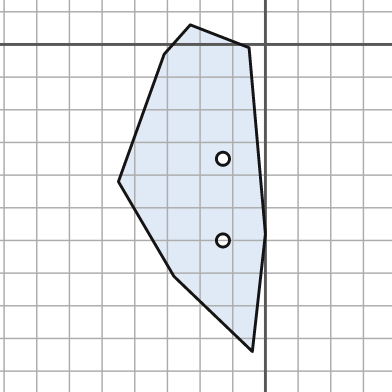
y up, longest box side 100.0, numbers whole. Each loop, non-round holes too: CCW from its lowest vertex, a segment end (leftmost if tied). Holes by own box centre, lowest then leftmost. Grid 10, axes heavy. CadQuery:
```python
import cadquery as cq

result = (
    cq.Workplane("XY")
    .moveTo(-4.0, -94.0)
    .lineTo(0.0, -58.0)
    .lineTo(-5.0, -1.0)
    .lineTo(-23.0, 6.0)
    .lineTo(-31.0, -3.0)
    .lineTo(-45.0, -42.0)
    .lineTo(-28.0, -71.0)
    .close()
    .moveTo(-13.0, -60.0)
    .circle(2.0)
    .moveTo(-13.0, -35.0)
    .circle(2.0)
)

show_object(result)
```